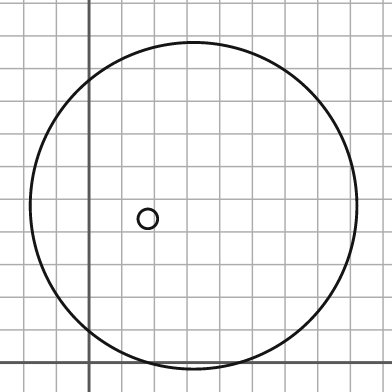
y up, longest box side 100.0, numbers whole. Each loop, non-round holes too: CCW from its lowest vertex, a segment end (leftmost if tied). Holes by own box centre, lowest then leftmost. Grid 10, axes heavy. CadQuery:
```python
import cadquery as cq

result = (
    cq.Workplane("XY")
    .moveTo(32.0, 48.0)
    .circle(50.0)
    .moveTo(18.0, 44.0)
    .circle(3.0)
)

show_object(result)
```